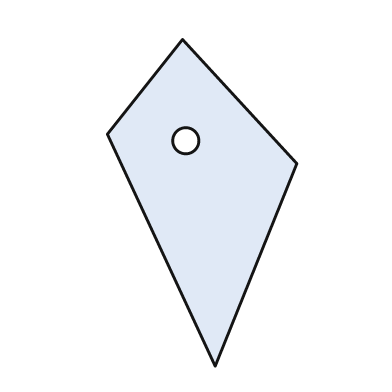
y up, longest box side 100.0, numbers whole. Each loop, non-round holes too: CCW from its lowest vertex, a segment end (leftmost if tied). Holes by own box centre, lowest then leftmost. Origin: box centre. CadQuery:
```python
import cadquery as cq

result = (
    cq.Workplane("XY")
    .moveTo(4.0, -50.0)
    .lineTo(29.0, 12.0)
    .lineTo(-6.0, 50.0)
    .lineTo(-29.0, 21.0)
    .close()
    .moveTo(-5.0, 19.0)
    .circle(4.0)
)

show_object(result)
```